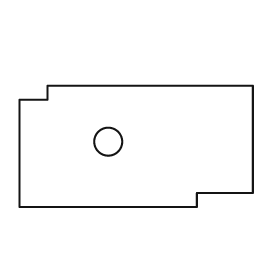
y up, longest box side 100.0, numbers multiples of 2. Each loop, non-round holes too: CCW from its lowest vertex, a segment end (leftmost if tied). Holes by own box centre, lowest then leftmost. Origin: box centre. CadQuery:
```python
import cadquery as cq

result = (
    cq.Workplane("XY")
    .moveTo(-50.0, -26.0)
    .lineTo(26.0, -26.0)
    .lineTo(26.0, -20.0)
    .lineTo(50.0, -20.0)
    .lineTo(50.0, 26.0)
    .lineTo(-38.0, 26.0)
    .lineTo(-38.0, 20.0)
    .lineTo(-50.0, 20.0)
    .close()
    .moveTo(-12.0, 2.0)
    .circle(6.0)
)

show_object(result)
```